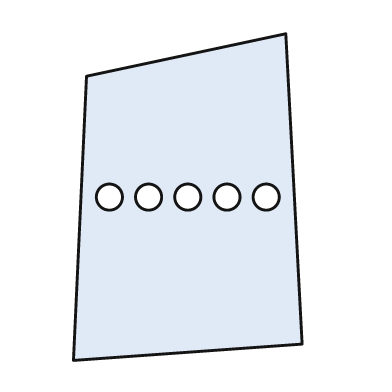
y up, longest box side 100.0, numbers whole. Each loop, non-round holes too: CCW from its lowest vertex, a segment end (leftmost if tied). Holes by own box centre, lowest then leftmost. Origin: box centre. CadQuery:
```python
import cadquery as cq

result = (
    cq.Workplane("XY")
    .moveTo(-35.0, -50.0)
    .lineTo(35.0, -45.0)
    .lineTo(30.0, 50.0)
    .lineTo(-31.0, 37.0)
    .close()
    .moveTo(-24.0, 0.0)
    .circle(4.0)
    .moveTo(-12.0, 0.0)
    .circle(4.0)
    .moveTo(0.0, 0.0)
    .circle(4.0)
    .moveTo(12.0, 0.0)
    .circle(4.0)
    .moveTo(24.0, 0.0)
    .circle(4.0)
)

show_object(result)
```